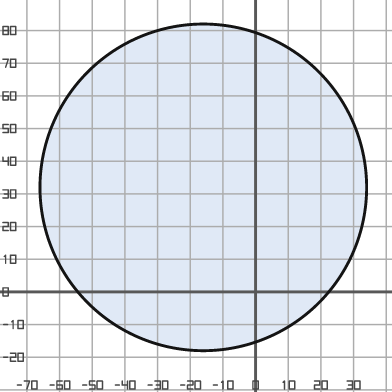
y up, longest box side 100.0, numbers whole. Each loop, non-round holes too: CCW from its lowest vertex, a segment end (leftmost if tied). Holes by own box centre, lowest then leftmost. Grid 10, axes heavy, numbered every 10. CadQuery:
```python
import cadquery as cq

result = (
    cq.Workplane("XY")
    .moveTo(-16.0, 32.0)
    .circle(50.0)
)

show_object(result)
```